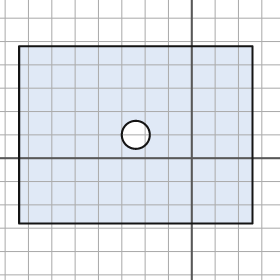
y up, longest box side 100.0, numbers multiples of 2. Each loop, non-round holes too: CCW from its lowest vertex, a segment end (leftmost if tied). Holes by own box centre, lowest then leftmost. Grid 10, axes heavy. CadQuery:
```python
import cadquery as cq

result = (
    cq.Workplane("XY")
    .moveTo(-74.0, -28.0)
    .lineTo(26.0, -28.0)
    .lineTo(26.0, 48.0)
    .lineTo(-74.0, 48.0)
    .close()
    .moveTo(-24.0, 10.0)
    .circle(6.0)
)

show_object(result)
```